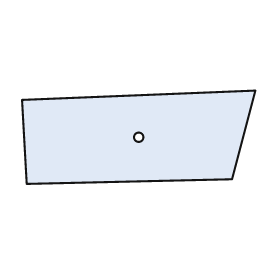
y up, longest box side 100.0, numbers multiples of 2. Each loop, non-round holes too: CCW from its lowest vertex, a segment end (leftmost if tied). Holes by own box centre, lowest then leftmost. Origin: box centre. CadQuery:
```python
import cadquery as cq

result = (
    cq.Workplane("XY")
    .moveTo(-48.0, -20.0)
    .lineTo(40.0, -18.0)
    .lineTo(50.0, 20.0)
    .lineTo(-50.0, 16.0)
    .close()
    .moveTo(0.0, 0.0)
    .circle(2.0)
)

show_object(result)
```